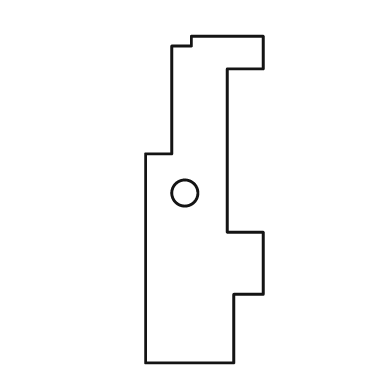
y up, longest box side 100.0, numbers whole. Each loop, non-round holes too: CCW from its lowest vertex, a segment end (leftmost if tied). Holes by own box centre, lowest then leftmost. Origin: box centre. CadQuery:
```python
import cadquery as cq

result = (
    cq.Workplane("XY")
    .moveTo(-18.0, -50.0)
    .lineTo(9.0, -50.0)
    .lineTo(9.0, -29.0)
    .lineTo(18.0, -29.0)
    .lineTo(18.0, -10.0)
    .lineTo(7.0, -10.0)
    .lineTo(7.0, 40.0)
    .lineTo(18.0, 40.0)
    .lineTo(18.0, 50.0)
    .lineTo(-4.0, 50.0)
    .lineTo(-4.0, 47.0)
    .lineTo(-10.0, 47.0)
    .lineTo(-10.0, 14.0)
    .lineTo(-18.0, 14.0)
    .close()
    .moveTo(-6.0, 2.0)
    .circle(4.0)
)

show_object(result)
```